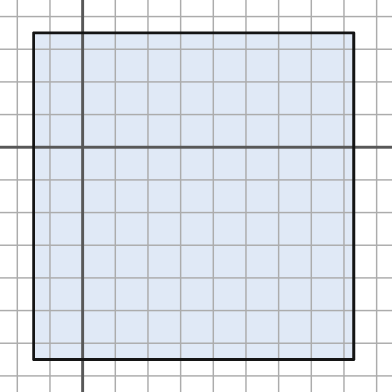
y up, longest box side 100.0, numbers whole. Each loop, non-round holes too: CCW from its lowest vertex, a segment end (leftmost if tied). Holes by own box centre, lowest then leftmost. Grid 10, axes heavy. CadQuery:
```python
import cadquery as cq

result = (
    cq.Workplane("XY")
    .moveTo(-15.0, -65.0)
    .lineTo(83.0, -65.0)
    .lineTo(83.0, 35.0)
    .lineTo(-15.0, 35.0)
    .close()
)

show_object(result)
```